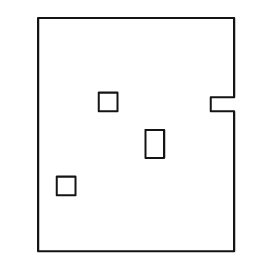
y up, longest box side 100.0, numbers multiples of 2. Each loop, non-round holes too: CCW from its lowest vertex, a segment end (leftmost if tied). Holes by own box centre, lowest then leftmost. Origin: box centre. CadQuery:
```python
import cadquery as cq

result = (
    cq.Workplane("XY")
    .moveTo(-42.0, -50.0)
    .lineTo(42.0, -50.0)
    .lineTo(42.0, 10.0)
    .lineTo(32.0, 10.0)
    .lineTo(32.0, 16.0)
    .lineTo(42.0, 16.0)
    .lineTo(42.0, 50.0)
    .lineTo(-42.0, 50.0)
    .close()
    .moveTo(-34.0, -26.0)
    .lineTo(-26.0, -26.0)
    .lineTo(-26.0, -18.0)
    .lineTo(-34.0, -18.0)
    .close()
    .moveTo(4.0, -10.0)
    .lineTo(12.0, -10.0)
    .lineTo(12.0, 2.0)
    .lineTo(4.0, 2.0)
    .close()
    .moveTo(-16.0, 10.0)
    .lineTo(-8.0, 10.0)
    .lineTo(-8.0, 18.0)
    .lineTo(-16.0, 18.0)
    .close()
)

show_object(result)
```